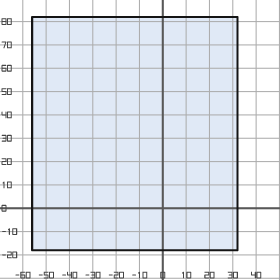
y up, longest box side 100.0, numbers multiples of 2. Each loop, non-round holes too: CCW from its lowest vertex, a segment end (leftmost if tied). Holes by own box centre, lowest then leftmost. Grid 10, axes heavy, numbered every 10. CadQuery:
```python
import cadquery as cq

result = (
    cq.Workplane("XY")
    .moveTo(-56.0, -18.0)
    .lineTo(32.0, -18.0)
    .lineTo(32.0, 82.0)
    .lineTo(-56.0, 82.0)
    .close()
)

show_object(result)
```